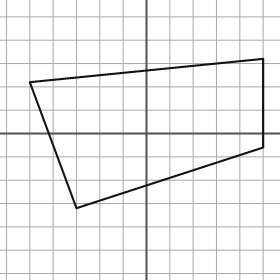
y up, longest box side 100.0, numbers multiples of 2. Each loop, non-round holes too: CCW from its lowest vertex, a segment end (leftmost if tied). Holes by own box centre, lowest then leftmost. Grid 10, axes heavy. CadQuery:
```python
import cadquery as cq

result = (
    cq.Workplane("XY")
    .moveTo(-30.0, -32.0)
    .lineTo(50.0, -6.0)
    .lineTo(50.0, 32.0)
    .lineTo(-50.0, 22.0)
    .close()
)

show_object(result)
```